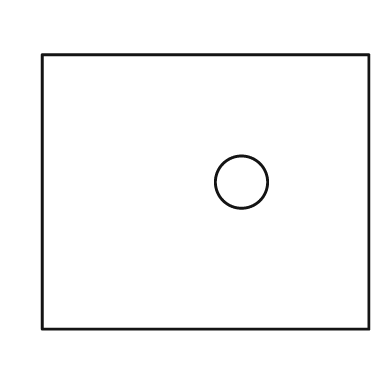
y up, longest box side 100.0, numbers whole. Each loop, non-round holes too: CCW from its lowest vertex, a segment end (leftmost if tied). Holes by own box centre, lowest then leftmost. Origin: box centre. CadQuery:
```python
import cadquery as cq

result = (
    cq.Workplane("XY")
    .moveTo(-50.0, -42.0)
    .lineTo(50.0, -42.0)
    .lineTo(50.0, 42.0)
    .lineTo(-50.0, 42.0)
    .close()
    .moveTo(11.0, 3.0)
    .circle(8.0)
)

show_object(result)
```